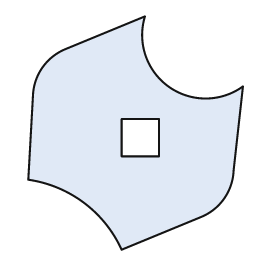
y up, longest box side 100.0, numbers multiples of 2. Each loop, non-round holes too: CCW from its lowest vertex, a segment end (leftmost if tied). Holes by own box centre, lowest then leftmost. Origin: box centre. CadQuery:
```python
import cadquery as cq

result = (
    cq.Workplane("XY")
    .moveTo(-6.0, -50.0)
    .lineTo(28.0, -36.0)
    .threePointArc((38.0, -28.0), (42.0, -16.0))
    .lineTo(46.0, 20.0)
    .threePointArc((14.0, 20.0), (4.0, 50.0))
    .lineTo(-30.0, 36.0)
    .threePointArc((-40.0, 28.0), (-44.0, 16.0))
    .lineTo(-46.0, -20.0)
    .threePointArc((-22.0, -30.0), (-6.0, -50.0))
    .close()
    .moveTo(-6.0, -10.0)
    .lineTo(10.0, -10.0)
    .lineTo(10.0, 6.0)
    .lineTo(-6.0, 6.0)
    .close()
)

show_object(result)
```